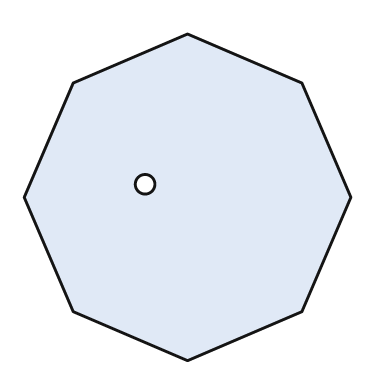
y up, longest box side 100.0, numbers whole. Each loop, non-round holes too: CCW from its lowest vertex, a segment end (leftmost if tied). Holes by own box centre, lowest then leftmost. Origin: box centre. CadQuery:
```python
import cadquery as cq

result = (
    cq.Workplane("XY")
    .moveTo(0.0, -50.0)
    .lineTo(35.0, -35.0)
    .lineTo(50.0, 0.0)
    .lineTo(35.0, 35.0)
    .lineTo(0.0, 50.0)
    .lineTo(-35.0, 35.0)
    .lineTo(-50.0, 0.0)
    .lineTo(-35.0, -35.0)
    .close()
    .moveTo(-13.0, 4.0)
    .circle(3.0)
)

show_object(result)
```